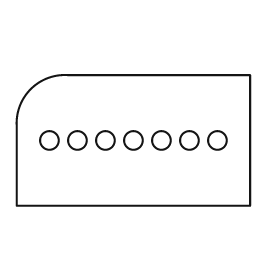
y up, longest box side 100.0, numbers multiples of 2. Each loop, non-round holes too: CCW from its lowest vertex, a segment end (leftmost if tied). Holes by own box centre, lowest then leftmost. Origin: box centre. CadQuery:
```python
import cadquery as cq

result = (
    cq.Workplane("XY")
    .moveTo(-50.0, -28.0)
    .lineTo(50.0, -28.0)
    .lineTo(50.0, 28.0)
    .lineTo(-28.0, 28.0)
    .threePointArc((-44.0, 22.0), (-50.0, 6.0))
    .close()
    .moveTo(-36.0, 0.0)
    .circle(4.0)
    .moveTo(-24.0, 0.0)
    .circle(4.0)
    .moveTo(-12.0, 0.0)
    .circle(4.0)
    .moveTo(0.0, 0.0)
    .circle(4.0)
    .moveTo(12.0, 0.0)
    .circle(4.0)
    .moveTo(24.0, 0.0)
    .circle(4.0)
    .moveTo(36.0, 0.0)
    .circle(4.0)
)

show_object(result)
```